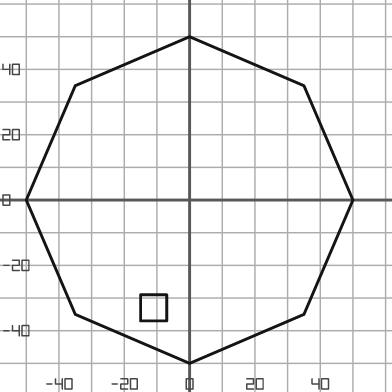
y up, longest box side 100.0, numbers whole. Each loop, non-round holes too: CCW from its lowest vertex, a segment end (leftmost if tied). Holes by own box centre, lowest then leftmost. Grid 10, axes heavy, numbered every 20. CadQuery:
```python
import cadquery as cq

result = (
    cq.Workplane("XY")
    .moveTo(0.0, -50.0)
    .lineTo(35.0, -35.0)
    .lineTo(50.0, 0.0)
    .lineTo(35.0, 35.0)
    .lineTo(0.0, 50.0)
    .lineTo(-35.0, 35.0)
    .lineTo(-50.0, 0.0)
    .lineTo(-35.0, -35.0)
    .close()
    .moveTo(-15.0, -37.0)
    .lineTo(-7.0, -37.0)
    .lineTo(-7.0, -29.0)
    .lineTo(-15.0, -29.0)
    .close()
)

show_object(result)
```